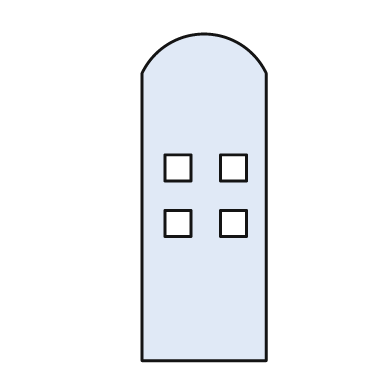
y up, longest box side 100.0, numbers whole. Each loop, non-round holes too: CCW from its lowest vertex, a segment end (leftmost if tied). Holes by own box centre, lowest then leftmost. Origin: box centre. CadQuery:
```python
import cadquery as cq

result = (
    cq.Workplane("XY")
    .moveTo(-19.0, -50.0)
    .lineTo(19.0, -50.0)
    .lineTo(19.0, 38.0)
    .threePointArc((0.0, 50.0), (-19.0, 38.0))
    .close()
    .moveTo(-12.0, -12.0)
    .lineTo(-4.0, -12.0)
    .lineTo(-4.0, -4.0)
    .lineTo(-12.0, -4.0)
    .close()
    .moveTo(5.0, -12.0)
    .lineTo(13.0, -12.0)
    .lineTo(13.0, -4.0)
    .lineTo(5.0, -4.0)
    .close()
    .moveTo(-12.0, 5.0)
    .lineTo(-4.0, 5.0)
    .lineTo(-4.0, 13.0)
    .lineTo(-12.0, 13.0)
    .close()
    .moveTo(5.0, 5.0)
    .lineTo(13.0, 5.0)
    .lineTo(13.0, 13.0)
    .lineTo(5.0, 13.0)
    .close()
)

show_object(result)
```